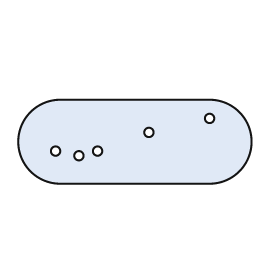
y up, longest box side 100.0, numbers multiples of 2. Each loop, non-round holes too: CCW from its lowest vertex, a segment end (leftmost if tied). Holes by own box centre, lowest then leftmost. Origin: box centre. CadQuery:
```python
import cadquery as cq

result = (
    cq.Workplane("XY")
    .moveTo(-32.0, -18.0)
    .lineTo(32.0, -18.0)
    .threePointArc((50.0, 0.0), (32.0, 18.0))
    .lineTo(-32.0, 18.0)
    .threePointArc((-50.0, 0.0), (-32.0, -18.0))
    .close()
    .moveTo(-24.0, -6.0)
    .circle(2.0)
    .moveTo(-34.0, -4.0)
    .circle(2.0)
    .moveTo(-16.0, -4.0)
    .circle(2.0)
    .moveTo(6.0, 4.0)
    .circle(2.0)
    .moveTo(32.0, 10.0)
    .circle(2.0)
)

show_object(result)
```